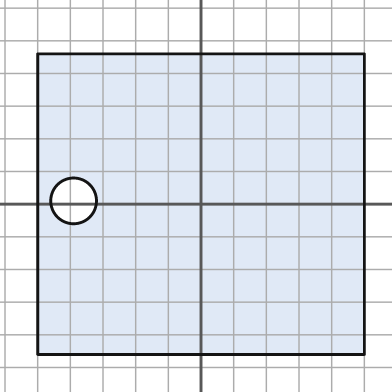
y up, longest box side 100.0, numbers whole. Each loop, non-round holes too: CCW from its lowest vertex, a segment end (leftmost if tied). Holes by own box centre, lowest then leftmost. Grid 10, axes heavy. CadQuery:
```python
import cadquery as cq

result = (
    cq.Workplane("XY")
    .moveTo(-50.0, -46.0)
    .lineTo(50.0, -46.0)
    .lineTo(50.0, 46.0)
    .lineTo(-50.0, 46.0)
    .close()
    .moveTo(-39.0, 1.0)
    .circle(7.0)
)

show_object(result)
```